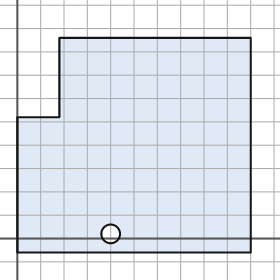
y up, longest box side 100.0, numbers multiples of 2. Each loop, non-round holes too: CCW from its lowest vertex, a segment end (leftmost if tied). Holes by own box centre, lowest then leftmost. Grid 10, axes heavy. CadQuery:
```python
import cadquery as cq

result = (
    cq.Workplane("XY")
    .moveTo(0.0, -6.0)
    .lineTo(100.0, -6.0)
    .lineTo(100.0, 86.0)
    .lineTo(18.0, 86.0)
    .lineTo(18.0, 52.0)
    .lineTo(0.0, 52.0)
    .close()
    .moveTo(40.0, 2.0)
    .circle(4.0)
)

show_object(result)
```